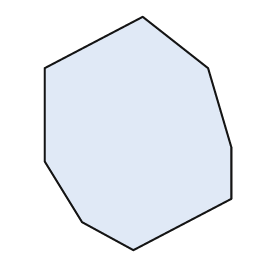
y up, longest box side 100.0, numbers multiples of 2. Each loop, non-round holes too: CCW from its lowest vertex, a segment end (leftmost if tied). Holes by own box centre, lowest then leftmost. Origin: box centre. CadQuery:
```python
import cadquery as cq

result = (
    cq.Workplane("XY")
    .moveTo(-2.0, -50.0)
    .lineTo(40.0, -28.0)
    .lineTo(40.0, -6.0)
    .lineTo(30.0, 28.0)
    .lineTo(2.0, 50.0)
    .lineTo(-40.0, 28.0)
    .lineTo(-40.0, -12.0)
    .lineTo(-24.0, -38.0)
    .close()
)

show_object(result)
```